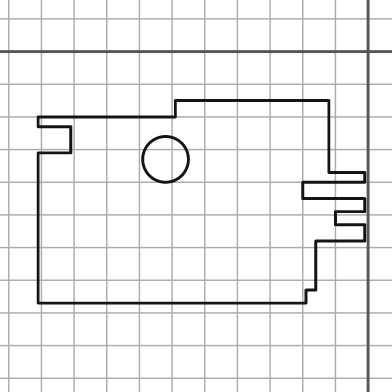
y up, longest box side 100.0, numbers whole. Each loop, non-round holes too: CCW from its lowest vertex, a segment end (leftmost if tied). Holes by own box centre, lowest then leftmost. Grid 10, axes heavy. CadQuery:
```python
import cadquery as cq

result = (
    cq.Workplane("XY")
    .moveTo(-101.0, -77.0)
    .lineTo(-19.0, -77.0)
    .lineTo(-19.0, -73.0)
    .lineTo(-16.0, -73.0)
    .lineTo(-16.0, -58.0)
    .lineTo(-1.0, -58.0)
    .lineTo(-1.0, -53.0)
    .lineTo(-10.0, -53.0)
    .lineTo(-10.0, -49.0)
    .lineTo(-1.0, -49.0)
    .lineTo(-1.0, -45.0)
    .lineTo(-20.0, -45.0)
    .lineTo(-20.0, -40.0)
    .lineTo(-1.0, -40.0)
    .lineTo(-1.0, -37.0)
    .lineTo(-12.0, -37.0)
    .lineTo(-12.0, -15.0)
    .lineTo(-59.0, -15.0)
    .lineTo(-59.0, -20.0)
    .lineTo(-101.0, -20.0)
    .lineTo(-101.0, -23.0)
    .lineTo(-91.0, -23.0)
    .lineTo(-91.0, -31.0)
    .lineTo(-101.0, -31.0)
    .close()
    .moveTo(-62.0, -33.0)
    .circle(7.0)
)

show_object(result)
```